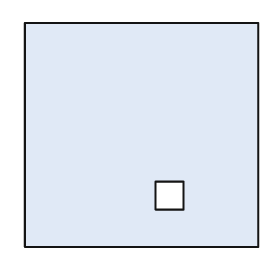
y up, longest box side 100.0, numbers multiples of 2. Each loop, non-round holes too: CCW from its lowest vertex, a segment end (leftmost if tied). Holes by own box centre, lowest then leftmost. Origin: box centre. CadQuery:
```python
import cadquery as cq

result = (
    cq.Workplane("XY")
    .moveTo(-50.0, -48.0)
    .lineTo(50.0, -48.0)
    .lineTo(50.0, 48.0)
    .lineTo(-50.0, 48.0)
    .close()
    .moveTo(6.0, -32.0)
    .lineTo(18.0, -32.0)
    .lineTo(18.0, -20.0)
    .lineTo(6.0, -20.0)
    .close()
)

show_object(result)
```